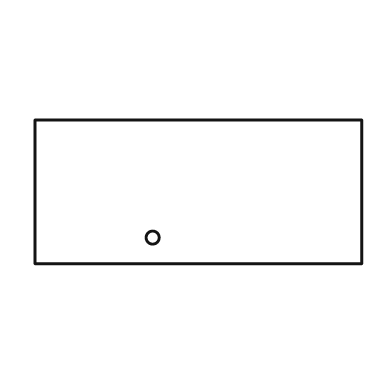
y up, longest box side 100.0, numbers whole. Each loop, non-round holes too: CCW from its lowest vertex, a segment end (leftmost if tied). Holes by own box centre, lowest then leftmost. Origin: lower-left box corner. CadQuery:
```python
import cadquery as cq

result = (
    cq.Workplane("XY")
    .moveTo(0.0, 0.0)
    .lineTo(100.0, 0.0)
    .lineTo(100.0, 44.0)
    .lineTo(0.0, 44.0)
    .close()
    .moveTo(36.0, 8.0)
    .circle(2.0)
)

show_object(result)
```